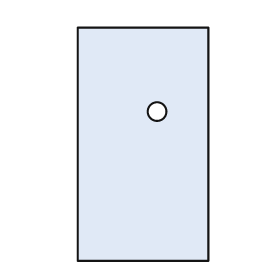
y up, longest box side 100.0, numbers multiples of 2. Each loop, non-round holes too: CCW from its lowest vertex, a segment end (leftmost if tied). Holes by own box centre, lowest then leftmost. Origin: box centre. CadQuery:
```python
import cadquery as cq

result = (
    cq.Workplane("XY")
    .moveTo(-28.0, -50.0)
    .lineTo(28.0, -50.0)
    .lineTo(28.0, 50.0)
    .lineTo(-28.0, 50.0)
    .close()
    .moveTo(6.0, 14.0)
    .circle(4.0)
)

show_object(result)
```